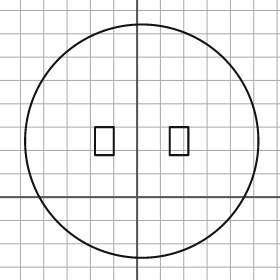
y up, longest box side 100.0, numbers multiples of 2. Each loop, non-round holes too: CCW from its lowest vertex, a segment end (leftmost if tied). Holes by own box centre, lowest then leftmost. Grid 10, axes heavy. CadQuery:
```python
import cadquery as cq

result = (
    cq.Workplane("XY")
    .moveTo(2.0, 24.0)
    .circle(50.0)
    .moveTo(-18.0, 18.0)
    .lineTo(-10.0, 18.0)
    .lineTo(-10.0, 30.0)
    .lineTo(-18.0, 30.0)
    .close()
    .moveTo(14.0, 18.0)
    .lineTo(22.0, 18.0)
    .lineTo(22.0, 30.0)
    .lineTo(14.0, 30.0)
    .close()
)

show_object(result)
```